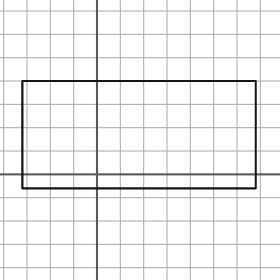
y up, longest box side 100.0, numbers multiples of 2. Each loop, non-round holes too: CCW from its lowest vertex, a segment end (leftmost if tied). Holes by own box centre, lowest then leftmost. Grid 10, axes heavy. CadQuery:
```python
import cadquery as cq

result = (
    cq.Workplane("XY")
    .moveTo(-32.0, -6.0)
    .lineTo(68.0, -6.0)
    .lineTo(68.0, 40.0)
    .lineTo(-32.0, 40.0)
    .close()
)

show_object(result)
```